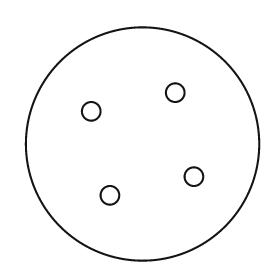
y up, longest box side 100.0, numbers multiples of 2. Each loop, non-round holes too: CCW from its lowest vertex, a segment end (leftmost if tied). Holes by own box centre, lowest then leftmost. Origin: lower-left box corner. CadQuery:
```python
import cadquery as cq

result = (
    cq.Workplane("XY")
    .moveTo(50.0, 50.0)
    .circle(50.0)
    .moveTo(36.0, 28.0)
    .circle(4.0)
    .moveTo(72.0, 36.0)
    .circle(4.0)
    .moveTo(28.0, 64.0)
    .circle(4.0)
    .moveTo(64.0, 72.0)
    .circle(4.0)
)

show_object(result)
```